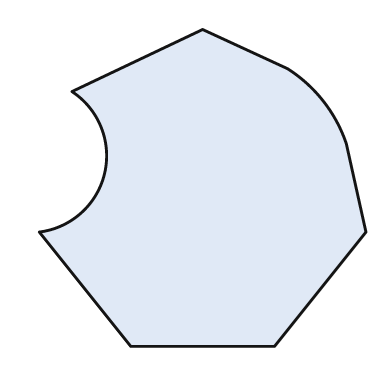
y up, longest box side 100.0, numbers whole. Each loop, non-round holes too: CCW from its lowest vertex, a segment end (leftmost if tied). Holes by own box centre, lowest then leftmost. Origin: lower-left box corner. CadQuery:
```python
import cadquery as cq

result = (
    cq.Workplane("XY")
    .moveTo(28.0, 0.0)
    .lineTo(72.0, 0.0)
    .lineTo(100.0, 35.0)
    .lineTo(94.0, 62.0)
    .threePointArc((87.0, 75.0), (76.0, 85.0))
    .lineTo(50.0, 97.0)
    .lineTo(10.0, 78.0)
    .threePointArc((20.0, 53.0), (0.0, 35.0))
    .close()
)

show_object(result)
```